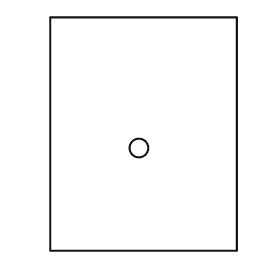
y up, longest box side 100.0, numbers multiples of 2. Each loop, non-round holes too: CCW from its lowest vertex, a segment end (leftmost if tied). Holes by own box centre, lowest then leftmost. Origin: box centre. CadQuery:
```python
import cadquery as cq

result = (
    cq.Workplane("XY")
    .moveTo(-40.0, -50.0)
    .lineTo(40.0, -50.0)
    .lineTo(40.0, 50.0)
    .lineTo(-40.0, 50.0)
    .close()
    .moveTo(-2.0, -6.0)
    .circle(4.0)
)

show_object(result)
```